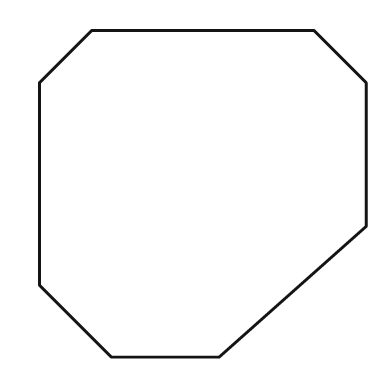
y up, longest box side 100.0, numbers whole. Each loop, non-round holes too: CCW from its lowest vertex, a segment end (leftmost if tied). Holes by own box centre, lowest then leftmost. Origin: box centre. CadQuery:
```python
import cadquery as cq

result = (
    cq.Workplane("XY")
    .moveTo(-28.0, -50.0)
    .lineTo(5.0, -50.0)
    .lineTo(50.0, -10.0)
    .lineTo(50.0, 34.0)
    .lineTo(34.0, 50.0)
    .lineTo(-34.0, 50.0)
    .lineTo(-50.0, 34.0)
    .lineTo(-50.0, -28.0)
    .close()
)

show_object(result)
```